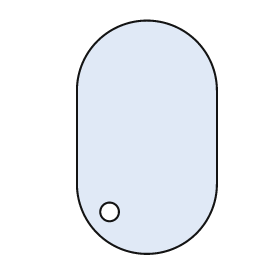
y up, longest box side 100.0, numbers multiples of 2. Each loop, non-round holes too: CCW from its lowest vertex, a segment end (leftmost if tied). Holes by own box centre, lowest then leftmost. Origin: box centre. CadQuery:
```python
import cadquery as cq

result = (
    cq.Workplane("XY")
    .moveTo(-30.0, -20.0)
    .threePointArc((0.0, -50.0), (30.0, -20.0))
    .lineTo(30.0, 20.0)
    .threePointArc((0.0, 50.0), (-30.0, 20.0))
    .close()
    .moveTo(-16.0, -32.0)
    .circle(4.0)
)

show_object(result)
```